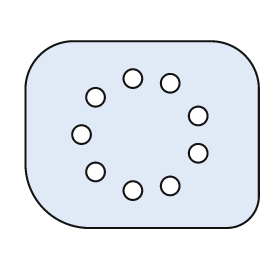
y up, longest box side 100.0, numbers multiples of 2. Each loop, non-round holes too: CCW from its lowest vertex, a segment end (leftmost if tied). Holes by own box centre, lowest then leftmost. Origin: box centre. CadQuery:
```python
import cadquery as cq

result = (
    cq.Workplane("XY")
    .moveTo(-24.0, -40.0)
    .lineTo(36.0, -40.0)
    .threePointArc((46.0, -36.0), (50.0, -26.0))
    .lineTo(50.0, 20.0)
    .threePointArc((44.0, 34.0), (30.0, 40.0))
    .lineTo(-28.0, 40.0)
    .threePointArc((-44.0, 34.0), (-50.0, 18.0))
    .lineTo(-50.0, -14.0)
    .threePointArc((-42.0, -32.0), (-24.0, -40.0))
    .close()
    .moveTo(-4.0, -24.0)
    .circle(4.0)
    .moveTo(12.0, -22.0)
    .circle(4.0)
    .moveTo(-20.0, -16.0)
    .circle(4.0)
    .moveTo(24.0, -8.0)
    .circle(4.0)
    .moveTo(-26.0, 0.0)
    .circle(4.0)
    .moveTo(24.0, 8.0)
    .circle(4.0)
    .moveTo(-20.0, 16.0)
    .circle(4.0)
    .moveTo(12.0, 22.0)
    .circle(4.0)
    .moveTo(-4.0, 24.0)
    .circle(4.0)
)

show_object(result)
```